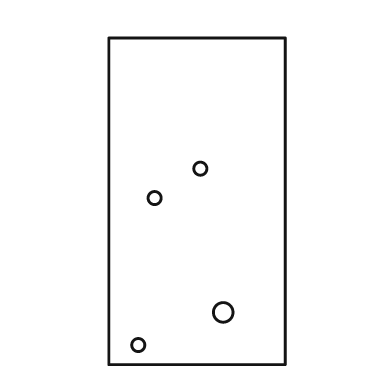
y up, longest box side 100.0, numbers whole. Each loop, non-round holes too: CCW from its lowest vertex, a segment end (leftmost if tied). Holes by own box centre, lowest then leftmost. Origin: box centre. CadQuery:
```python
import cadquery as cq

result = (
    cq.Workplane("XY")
    .moveTo(-27.0, -50.0)
    .lineTo(27.0, -50.0)
    .lineTo(27.0, 50.0)
    .lineTo(-27.0, 50.0)
    .close()
    .moveTo(-18.0, -44.0)
    .circle(2.0)
    .moveTo(8.0, -34.0)
    .circle(3.0)
    .moveTo(-13.0, 1.0)
    .circle(2.0)
    .moveTo(1.0, 10.0)
    .circle(2.0)
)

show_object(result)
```